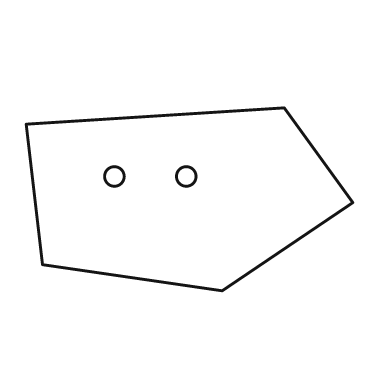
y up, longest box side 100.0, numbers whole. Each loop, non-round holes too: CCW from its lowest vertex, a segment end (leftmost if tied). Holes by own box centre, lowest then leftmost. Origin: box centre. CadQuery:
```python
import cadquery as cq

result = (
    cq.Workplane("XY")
    .moveTo(10.0, -28.0)
    .lineTo(50.0, -1.0)
    .lineTo(29.0, 28.0)
    .lineTo(-50.0, 23.0)
    .lineTo(-45.0, -20.0)
    .close()
    .moveTo(-23.0, 7.0)
    .circle(3.0)
    .moveTo(-1.0, 7.0)
    .circle(3.0)
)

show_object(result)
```